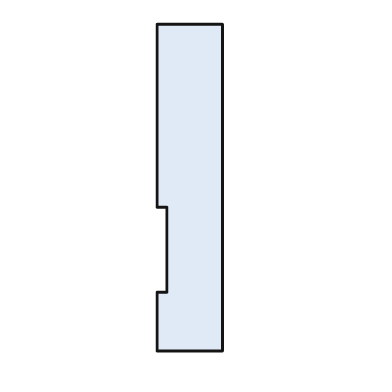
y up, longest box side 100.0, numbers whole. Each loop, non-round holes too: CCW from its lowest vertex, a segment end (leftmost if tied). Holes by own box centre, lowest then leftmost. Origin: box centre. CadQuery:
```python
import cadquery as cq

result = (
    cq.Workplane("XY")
    .moveTo(-10.0, -50.0)
    .lineTo(10.0, -50.0)
    .lineTo(10.0, 50.0)
    .lineTo(-10.0, 50.0)
    .lineTo(-10.0, -6.0)
    .lineTo(-7.0, -6.0)
    .lineTo(-7.0, -32.0)
    .lineTo(-10.0, -32.0)
    .close()
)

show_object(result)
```